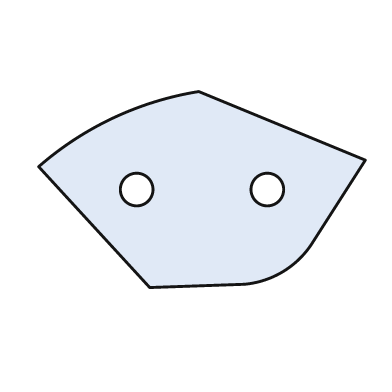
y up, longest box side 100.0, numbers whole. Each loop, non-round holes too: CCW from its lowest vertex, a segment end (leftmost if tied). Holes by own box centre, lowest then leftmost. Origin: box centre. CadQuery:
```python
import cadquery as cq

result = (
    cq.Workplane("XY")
    .moveTo(-16.0, -30.0)
    .lineTo(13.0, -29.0)
    .threePointArc((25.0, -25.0), (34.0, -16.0))
    .lineTo(50.0, 9.0)
    .lineTo(-1.0, 30.0)
    .threePointArc((-27.0, 22.0), (-50.0, 7.0))
    .close()
    .moveTo(-20.0, 0.0)
    .circle(5.0)
    .moveTo(20.0, 0.0)
    .circle(5.0)
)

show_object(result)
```